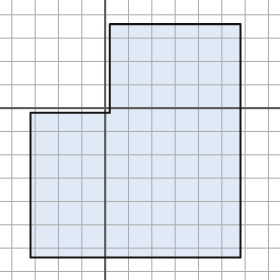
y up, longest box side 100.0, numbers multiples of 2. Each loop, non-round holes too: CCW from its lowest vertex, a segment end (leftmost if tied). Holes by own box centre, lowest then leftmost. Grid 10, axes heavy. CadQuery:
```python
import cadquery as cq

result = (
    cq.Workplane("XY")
    .moveTo(-32.0, -64.0)
    .lineTo(58.0, -64.0)
    .lineTo(58.0, 36.0)
    .lineTo(2.0, 36.0)
    .lineTo(2.0, -2.0)
    .lineTo(-32.0, -2.0)
    .close()
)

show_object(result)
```